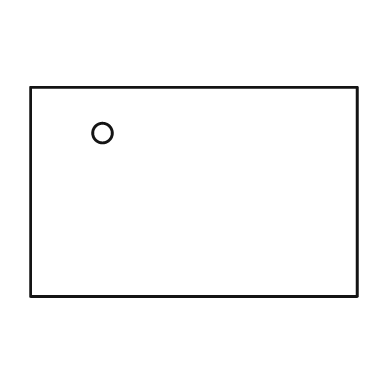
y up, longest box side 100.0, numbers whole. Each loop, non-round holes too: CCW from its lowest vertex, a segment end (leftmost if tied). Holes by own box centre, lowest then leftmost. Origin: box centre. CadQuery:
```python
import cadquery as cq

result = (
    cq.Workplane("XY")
    .moveTo(-50.0, -32.0)
    .lineTo(50.0, -32.0)
    .lineTo(50.0, 32.0)
    .lineTo(-50.0, 32.0)
    .close()
    .moveTo(-28.0, 18.0)
    .circle(3.0)
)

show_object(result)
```